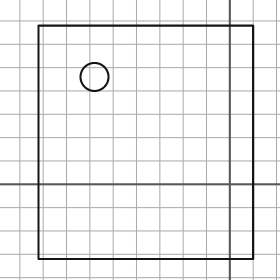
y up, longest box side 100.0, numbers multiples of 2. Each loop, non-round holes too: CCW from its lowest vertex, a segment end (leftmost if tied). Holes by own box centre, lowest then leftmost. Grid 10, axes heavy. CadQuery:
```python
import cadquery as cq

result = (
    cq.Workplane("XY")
    .moveTo(-82.0, -32.0)
    .lineTo(10.0, -32.0)
    .lineTo(10.0, 68.0)
    .lineTo(-82.0, 68.0)
    .close()
    .moveTo(-58.0, 46.0)
    .circle(6.0)
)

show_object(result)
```